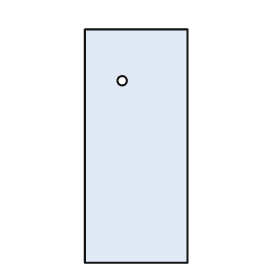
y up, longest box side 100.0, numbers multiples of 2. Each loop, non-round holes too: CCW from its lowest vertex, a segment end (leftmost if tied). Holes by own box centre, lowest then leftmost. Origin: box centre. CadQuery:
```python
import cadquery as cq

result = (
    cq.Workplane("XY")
    .moveTo(-22.0, -50.0)
    .lineTo(22.0, -50.0)
    .lineTo(22.0, 50.0)
    .lineTo(-22.0, 50.0)
    .close()
    .moveTo(-6.0, 28.0)
    .circle(2.0)
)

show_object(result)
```